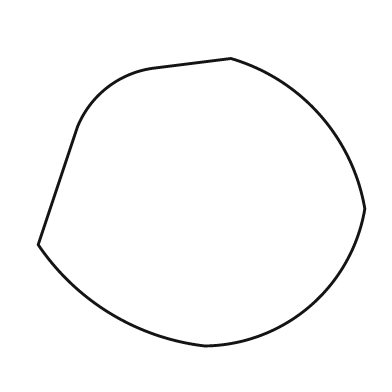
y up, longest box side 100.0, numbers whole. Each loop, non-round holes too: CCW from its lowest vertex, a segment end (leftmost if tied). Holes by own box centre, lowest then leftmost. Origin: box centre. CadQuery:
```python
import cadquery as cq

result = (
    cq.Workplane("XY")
    .moveTo(1.0, -44.0)
    .threePointArc((33.0, -32.0), (50.0, -2.0))
    .threePointArc((36.0, 27.0), (9.0, 44.0))
    .lineTo(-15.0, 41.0)
    .threePointArc((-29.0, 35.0), (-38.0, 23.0))
    .lineTo(-50.0, -13.0)
    .threePointArc((-28.0, -34.0), (1.0, -44.0))
    .close()
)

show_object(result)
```